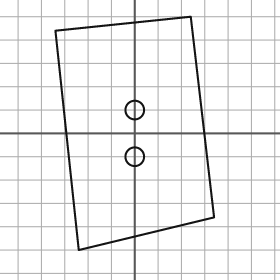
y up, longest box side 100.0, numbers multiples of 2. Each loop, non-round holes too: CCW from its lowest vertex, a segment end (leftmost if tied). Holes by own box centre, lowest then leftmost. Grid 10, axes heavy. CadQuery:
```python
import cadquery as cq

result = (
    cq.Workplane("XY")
    .moveTo(-24.0, -50.0)
    .lineTo(34.0, -36.0)
    .lineTo(24.0, 50.0)
    .lineTo(-34.0, 44.0)
    .close()
    .moveTo(0.0, -10.0)
    .circle(4.0)
    .moveTo(0.0, 10.0)
    .circle(4.0)
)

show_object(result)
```